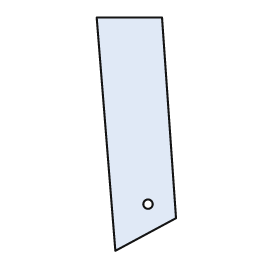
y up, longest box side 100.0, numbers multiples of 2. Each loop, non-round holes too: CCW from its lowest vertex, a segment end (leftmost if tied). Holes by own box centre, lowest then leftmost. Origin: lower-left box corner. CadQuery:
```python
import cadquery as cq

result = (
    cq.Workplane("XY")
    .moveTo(8.0, 0.0)
    .lineTo(34.0, 14.0)
    .lineTo(28.0, 100.0)
    .lineTo(0.0, 100.0)
    .close()
    .moveTo(22.0, 20.0)
    .circle(2.0)
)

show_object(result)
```